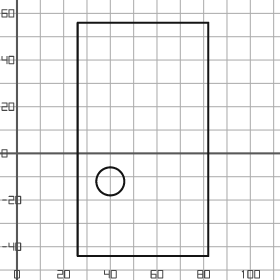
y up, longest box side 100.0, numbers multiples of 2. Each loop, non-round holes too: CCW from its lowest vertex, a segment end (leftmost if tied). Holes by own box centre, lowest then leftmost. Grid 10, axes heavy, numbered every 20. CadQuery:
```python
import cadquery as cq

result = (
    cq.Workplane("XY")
    .moveTo(26.0, -44.0)
    .lineTo(82.0, -44.0)
    .lineTo(82.0, 56.0)
    .lineTo(26.0, 56.0)
    .close()
    .moveTo(40.0, -12.0)
    .circle(6.0)
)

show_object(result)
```